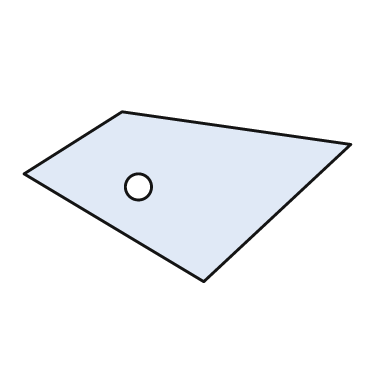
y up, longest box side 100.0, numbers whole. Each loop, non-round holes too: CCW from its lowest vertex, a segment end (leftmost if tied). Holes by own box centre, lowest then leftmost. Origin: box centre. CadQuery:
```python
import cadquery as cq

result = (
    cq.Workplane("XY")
    .moveTo(5.0, -26.0)
    .lineTo(50.0, 16.0)
    .lineTo(-20.0, 26.0)
    .lineTo(-50.0, 7.0)
    .close()
    .moveTo(-15.0, 3.0)
    .circle(4.0)
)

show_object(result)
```